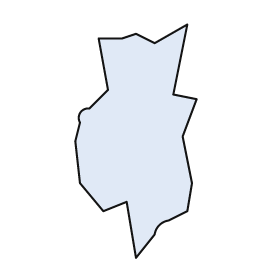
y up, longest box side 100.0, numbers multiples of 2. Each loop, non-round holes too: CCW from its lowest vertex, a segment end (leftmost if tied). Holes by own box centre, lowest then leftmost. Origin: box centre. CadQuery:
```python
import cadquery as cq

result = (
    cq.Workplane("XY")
    .moveTo(0.0, -50.0)
    .lineTo(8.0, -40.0)
    .threePointArc((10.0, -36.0), (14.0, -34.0))
    .lineTo(22.0, -30.0)
    .lineTo(24.0, -18.0)
    .lineTo(20.0, 2.0)
    .lineTo(26.0, 18.0)
    .lineTo(16.0, 20.0)
    .lineTo(22.0, 50.0)
    .lineTo(8.0, 42.0)
    .lineTo(0.0, 46.0)
    .lineTo(-6.0, 44.0)
    .lineTo(-16.0, 44.0)
    .lineTo(-12.0, 22.0)
    .lineTo(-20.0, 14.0)
    .threePointArc((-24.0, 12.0), (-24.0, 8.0))
    .lineTo(-26.0, 0.0)
    .lineTo(-24.0, -18.0)
    .lineTo(-14.0, -30.0)
    .lineTo(-4.0, -26.0)
    .close()
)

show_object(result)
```